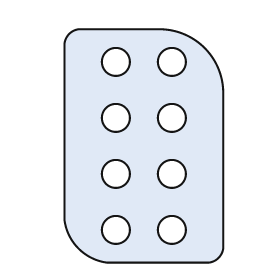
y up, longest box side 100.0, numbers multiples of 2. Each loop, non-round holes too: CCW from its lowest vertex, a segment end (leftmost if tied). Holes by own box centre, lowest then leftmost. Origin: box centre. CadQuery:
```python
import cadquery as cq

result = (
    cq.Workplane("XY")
    .moveTo(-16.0, -50.0)
    .lineTo(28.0, -50.0)
    .threePointArc((32.0, -48.0), (34.0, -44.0))
    .lineTo(34.0, 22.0)
    .threePointArc((26.0, 42.0), (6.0, 50.0))
    .lineTo(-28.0, 50.0)
    .threePointArc((-32.0, 48.0), (-34.0, 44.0))
    .lineTo(-34.0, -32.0)
    .threePointArc((-28.0, -44.0), (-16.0, -50.0))
    .close()
    .moveTo(-12.0, -36.0)
    .circle(6.0)
    .moveTo(12.0, -36.0)
    .circle(6.0)
    .moveTo(-12.0, -12.0)
    .circle(6.0)
    .moveTo(12.0, -12.0)
    .circle(6.0)
    .moveTo(-12.0, 12.0)
    .circle(6.0)
    .moveTo(12.0, 12.0)
    .circle(6.0)
    .moveTo(-12.0, 36.0)
    .circle(6.0)
    .moveTo(12.0, 36.0)
    .circle(6.0)
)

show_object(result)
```